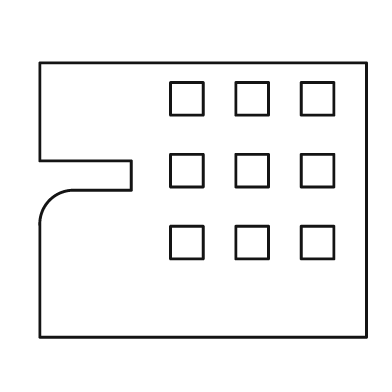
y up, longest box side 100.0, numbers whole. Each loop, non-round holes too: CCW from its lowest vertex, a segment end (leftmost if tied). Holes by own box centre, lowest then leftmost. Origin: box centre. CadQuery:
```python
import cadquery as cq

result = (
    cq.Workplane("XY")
    .moveTo(-50.0, -42.0)
    .lineTo(50.0, -42.0)
    .lineTo(50.0, 42.0)
    .lineTo(-50.0, 42.0)
    .lineTo(-50.0, 12.0)
    .lineTo(-22.0, 12.0)
    .lineTo(-22.0, 3.0)
    .lineTo(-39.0, 3.0)
    .threePointArc((-47.0, 0.0), (-50.0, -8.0))
    .close()
    .moveTo(-10.0, -18.0)
    .lineTo(0.0, -18.0)
    .lineTo(0.0, -8.0)
    .lineTo(-10.0, -8.0)
    .close()
    .moveTo(10.0, -18.0)
    .lineTo(20.0, -18.0)
    .lineTo(20.0, -8.0)
    .lineTo(10.0, -8.0)
    .close()
    .moveTo(30.0, -18.0)
    .lineTo(40.0, -18.0)
    .lineTo(40.0, -8.0)
    .lineTo(30.0, -8.0)
    .close()
    .moveTo(-10.0, 4.0)
    .lineTo(0.0, 4.0)
    .lineTo(0.0, 14.0)
    .lineTo(-10.0, 14.0)
    .close()
    .moveTo(10.0, 4.0)
    .lineTo(20.0, 4.0)
    .lineTo(20.0, 14.0)
    .lineTo(10.0, 14.0)
    .close()
    .moveTo(30.0, 4.0)
    .lineTo(40.0, 4.0)
    .lineTo(40.0, 14.0)
    .lineTo(30.0, 14.0)
    .close()
    .moveTo(-10.0, 26.0)
    .lineTo(0.0, 26.0)
    .lineTo(0.0, 36.0)
    .lineTo(-10.0, 36.0)
    .close()
    .moveTo(10.0, 26.0)
    .lineTo(20.0, 26.0)
    .lineTo(20.0, 36.0)
    .lineTo(10.0, 36.0)
    .close()
    .moveTo(30.0, 26.0)
    .lineTo(40.0, 26.0)
    .lineTo(40.0, 36.0)
    .lineTo(30.0, 36.0)
    .close()
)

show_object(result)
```